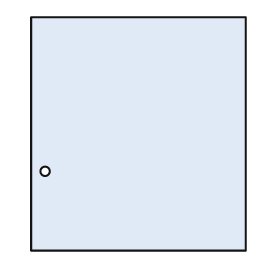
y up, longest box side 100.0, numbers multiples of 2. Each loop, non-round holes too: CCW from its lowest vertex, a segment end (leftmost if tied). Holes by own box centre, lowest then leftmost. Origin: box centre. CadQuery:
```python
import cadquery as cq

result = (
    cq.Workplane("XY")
    .moveTo(-46.0, -50.0)
    .lineTo(46.0, -50.0)
    .lineTo(46.0, 50.0)
    .lineTo(-46.0, 50.0)
    .close()
    .moveTo(-40.0, -16.0)
    .circle(2.0)
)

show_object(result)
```